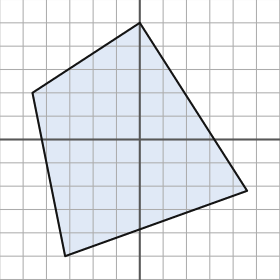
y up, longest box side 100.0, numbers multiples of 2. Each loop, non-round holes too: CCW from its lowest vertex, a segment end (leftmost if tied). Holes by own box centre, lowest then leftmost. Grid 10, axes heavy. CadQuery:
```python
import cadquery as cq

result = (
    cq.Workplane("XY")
    .moveTo(-32.0, -50.0)
    .lineTo(46.0, -22.0)
    .lineTo(0.0, 50.0)
    .lineTo(-46.0, 20.0)
    .close()
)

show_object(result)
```